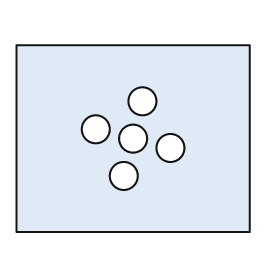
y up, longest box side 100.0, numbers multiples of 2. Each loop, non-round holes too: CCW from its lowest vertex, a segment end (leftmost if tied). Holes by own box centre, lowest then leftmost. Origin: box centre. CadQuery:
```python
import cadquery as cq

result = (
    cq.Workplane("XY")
    .moveTo(-50.0, -40.0)
    .lineTo(50.0, -40.0)
    .lineTo(50.0, 40.0)
    .lineTo(-50.0, 40.0)
    .close()
    .moveTo(-4.0, -16.0)
    .circle(6.0)
    .moveTo(16.0, -4.0)
    .circle(6.0)
    .moveTo(0.0, 0.0)
    .circle(6.0)
    .moveTo(-16.0, 4.0)
    .circle(6.0)
    .moveTo(4.0, 16.0)
    .circle(6.0)
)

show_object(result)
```